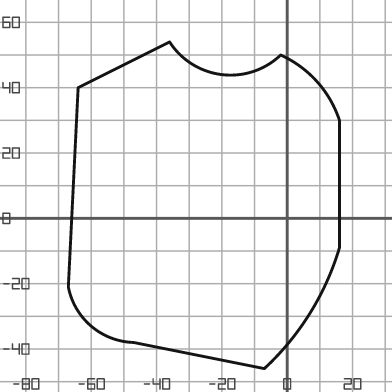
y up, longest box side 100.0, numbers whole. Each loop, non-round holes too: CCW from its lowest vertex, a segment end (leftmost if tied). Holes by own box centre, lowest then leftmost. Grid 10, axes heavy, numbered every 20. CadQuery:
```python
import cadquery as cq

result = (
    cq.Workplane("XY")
    .moveTo(-7.0, -46.0)
    .threePointArc((7.0, -29.0), (16.0, -9.0))
    .lineTo(16.0, 30.0)
    .threePointArc((9.0, 42.0), (-2.0, 50.0))
    .threePointArc((-20.0, 44.0), (-36.0, 54.0))
    .lineTo(-64.0, 40.0)
    .lineTo(-67.0, -21.0)
    .threePointArc((-60.0, -33.0), (-47.0, -38.0))
    .close()
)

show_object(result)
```